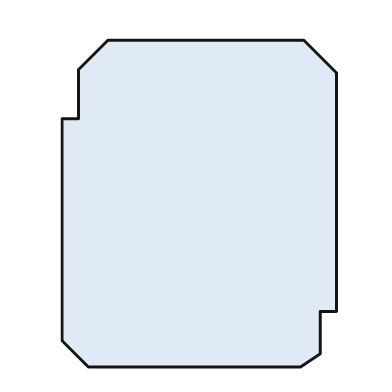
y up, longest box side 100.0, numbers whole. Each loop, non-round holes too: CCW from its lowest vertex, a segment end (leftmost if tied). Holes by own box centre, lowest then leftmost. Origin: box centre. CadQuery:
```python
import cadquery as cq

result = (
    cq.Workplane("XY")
    .moveTo(-34.0, -50.0)
    .lineTo(31.0, -50.0)
    .lineTo(37.0, -46.0)
    .lineTo(37.0, -33.0)
    .lineTo(42.0, -33.0)
    .lineTo(42.0, 40.0)
    .lineTo(32.0, 50.0)
    .lineTo(-28.0, 50.0)
    .lineTo(-37.0, 41.0)
    .lineTo(-37.0, 26.0)
    .lineTo(-42.0, 26.0)
    .lineTo(-42.0, -42.0)
    .close()
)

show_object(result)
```